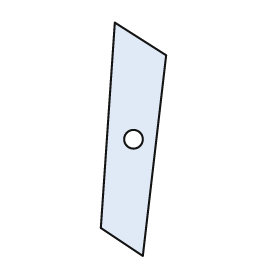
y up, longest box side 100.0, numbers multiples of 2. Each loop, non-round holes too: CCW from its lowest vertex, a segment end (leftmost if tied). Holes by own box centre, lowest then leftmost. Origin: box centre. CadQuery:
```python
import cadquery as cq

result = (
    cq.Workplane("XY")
    .moveTo(4.0, -50.0)
    .lineTo(14.0, 36.0)
    .lineTo(-8.0, 50.0)
    .lineTo(-14.0, -38.0)
    .close()
    .moveTo(0.0, 0.0)
    .circle(4.0)
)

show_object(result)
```